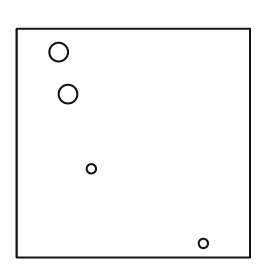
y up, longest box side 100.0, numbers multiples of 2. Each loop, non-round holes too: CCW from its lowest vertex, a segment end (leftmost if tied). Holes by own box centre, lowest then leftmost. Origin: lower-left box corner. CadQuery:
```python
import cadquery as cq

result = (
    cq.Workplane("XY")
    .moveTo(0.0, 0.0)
    .lineTo(100.0, 0.0)
    .lineTo(100.0, 98.0)
    .lineTo(0.0, 98.0)
    .close()
    .moveTo(80.0, 6.0)
    .circle(2.0)
    .moveTo(32.0, 38.0)
    .circle(2.0)
    .moveTo(22.0, 70.0)
    .circle(4.0)
    .moveTo(18.0, 88.0)
    .circle(4.0)
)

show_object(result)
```